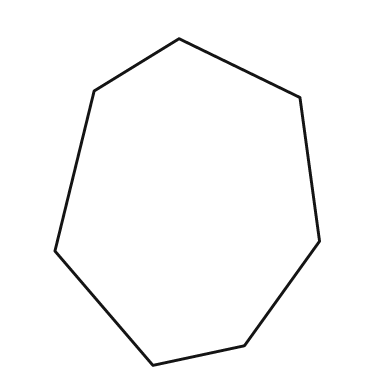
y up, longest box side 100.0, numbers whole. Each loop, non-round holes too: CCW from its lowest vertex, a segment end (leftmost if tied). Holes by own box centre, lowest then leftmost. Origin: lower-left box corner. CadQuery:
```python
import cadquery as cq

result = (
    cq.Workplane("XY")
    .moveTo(30.0, 0.0)
    .lineTo(58.0, 6.0)
    .lineTo(81.0, 38.0)
    .lineTo(75.0, 82.0)
    .lineTo(38.0, 100.0)
    .lineTo(12.0, 84.0)
    .lineTo(0.0, 35.0)
    .close()
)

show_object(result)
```